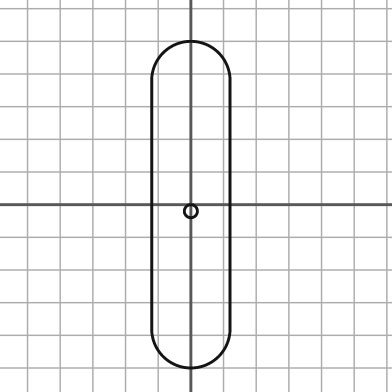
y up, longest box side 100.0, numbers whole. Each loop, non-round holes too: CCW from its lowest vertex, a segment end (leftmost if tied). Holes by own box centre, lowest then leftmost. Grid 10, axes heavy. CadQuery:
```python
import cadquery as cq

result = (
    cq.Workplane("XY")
    .moveTo(-12.0, -38.0)
    .threePointArc((0.0, -50.0), (12.0, -38.0))
    .lineTo(12.0, 38.0)
    .threePointArc((0.0, 50.0), (-12.0, 38.0))
    .close()
    .moveTo(0.0, -2.0)
    .circle(2.0)
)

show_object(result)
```